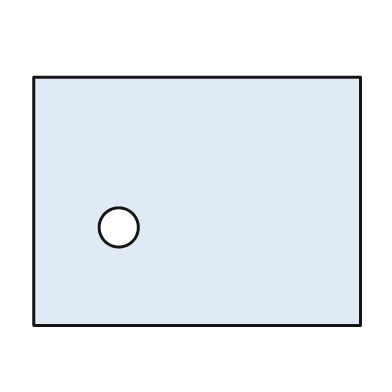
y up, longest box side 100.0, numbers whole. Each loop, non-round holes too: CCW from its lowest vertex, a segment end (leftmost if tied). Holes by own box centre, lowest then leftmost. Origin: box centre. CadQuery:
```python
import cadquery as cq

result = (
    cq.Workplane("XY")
    .moveTo(-50.0, -38.0)
    .lineTo(50.0, -38.0)
    .lineTo(50.0, 38.0)
    .lineTo(-50.0, 38.0)
    .close()
    .moveTo(-24.0, -8.0)
    .circle(6.0)
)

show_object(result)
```